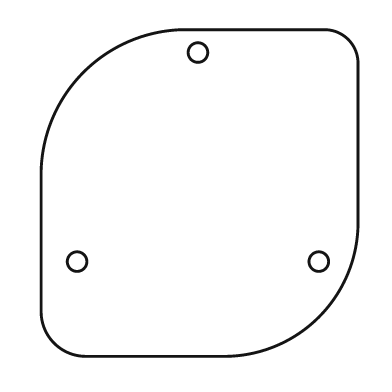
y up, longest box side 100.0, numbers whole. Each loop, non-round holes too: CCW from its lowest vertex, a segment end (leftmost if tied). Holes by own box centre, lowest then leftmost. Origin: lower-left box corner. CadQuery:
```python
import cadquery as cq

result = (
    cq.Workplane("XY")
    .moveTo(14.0, 0.0)
    .lineTo(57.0, 0.0)
    .threePointArc((85.0, 12.0), (97.0, 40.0))
    .lineTo(97.0, 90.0)
    .threePointArc((94.0, 97.0), (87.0, 100.0))
    .lineTo(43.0, 100.0)
    .threePointArc((13.0, 87.0), (0.0, 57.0))
    .lineTo(0.0, 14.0)
    .threePointArc((4.0, 4.0), (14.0, 0.0))
    .close()
    .moveTo(11.0, 29.0)
    .circle(3.0)
    .moveTo(85.0, 29.0)
    .circle(3.0)
    .moveTo(48.0, 93.0)
    .circle(3.0)
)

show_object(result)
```